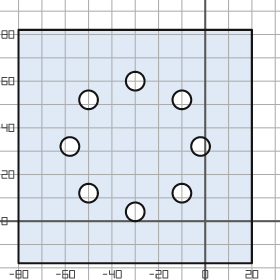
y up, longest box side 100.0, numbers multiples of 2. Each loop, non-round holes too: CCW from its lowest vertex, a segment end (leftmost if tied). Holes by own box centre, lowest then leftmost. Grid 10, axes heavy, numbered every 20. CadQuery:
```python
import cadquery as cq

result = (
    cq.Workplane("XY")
    .moveTo(-80.0, -18.0)
    .lineTo(20.0, -18.0)
    .lineTo(20.0, 82.0)
    .lineTo(-80.0, 82.0)
    .close()
    .moveTo(-30.0, 4.0)
    .circle(4.0)
    .moveTo(-50.0, 12.0)
    .circle(4.0)
    .moveTo(-10.0, 12.0)
    .circle(4.0)
    .moveTo(-58.0, 32.0)
    .circle(4.0)
    .moveTo(-2.0, 32.0)
    .circle(4.0)
    .moveTo(-50.0, 52.0)
    .circle(4.0)
    .moveTo(-10.0, 52.0)
    .circle(4.0)
    .moveTo(-30.0, 60.0)
    .circle(4.0)
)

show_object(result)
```